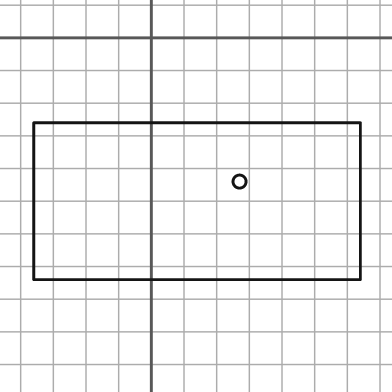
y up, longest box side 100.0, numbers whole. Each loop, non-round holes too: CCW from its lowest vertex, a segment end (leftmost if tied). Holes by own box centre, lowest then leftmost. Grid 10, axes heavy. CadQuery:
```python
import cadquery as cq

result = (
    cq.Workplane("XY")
    .moveTo(-36.0, -74.0)
    .lineTo(64.0, -74.0)
    .lineTo(64.0, -26.0)
    .lineTo(-36.0, -26.0)
    .close()
    .moveTo(27.0, -44.0)
    .circle(2.0)
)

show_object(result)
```